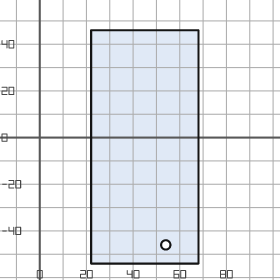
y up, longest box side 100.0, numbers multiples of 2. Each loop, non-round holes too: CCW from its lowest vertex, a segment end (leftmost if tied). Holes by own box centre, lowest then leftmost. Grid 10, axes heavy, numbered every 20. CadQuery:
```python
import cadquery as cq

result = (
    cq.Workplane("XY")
    .moveTo(22.0, -54.0)
    .lineTo(68.0, -54.0)
    .lineTo(68.0, 46.0)
    .lineTo(22.0, 46.0)
    .close()
    .moveTo(54.0, -46.0)
    .circle(2.0)
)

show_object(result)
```